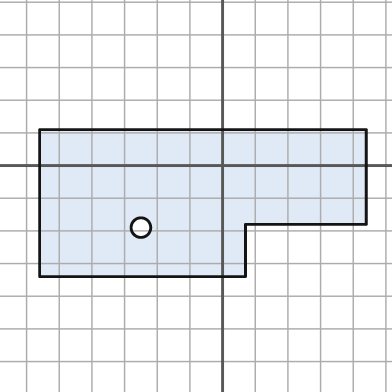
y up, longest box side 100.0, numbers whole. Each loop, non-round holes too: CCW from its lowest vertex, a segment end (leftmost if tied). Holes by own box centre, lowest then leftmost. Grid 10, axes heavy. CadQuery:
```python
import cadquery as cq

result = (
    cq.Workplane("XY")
    .moveTo(-56.0, -34.0)
    .lineTo(7.0, -34.0)
    .lineTo(7.0, -18.0)
    .lineTo(44.0, -18.0)
    .lineTo(44.0, 11.0)
    .lineTo(-56.0, 11.0)
    .close()
    .moveTo(-25.0, -19.0)
    .circle(3.0)
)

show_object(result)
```